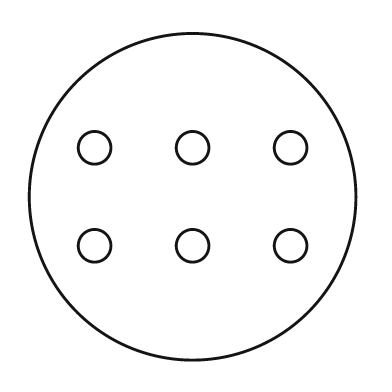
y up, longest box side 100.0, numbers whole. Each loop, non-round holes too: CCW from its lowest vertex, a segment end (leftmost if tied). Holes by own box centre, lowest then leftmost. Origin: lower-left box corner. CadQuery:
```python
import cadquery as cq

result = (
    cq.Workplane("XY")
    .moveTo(50.0, 50.0)
    .circle(50.0)
    .moveTo(20.0, 35.0)
    .circle(5.0)
    .moveTo(50.0, 35.0)
    .circle(5.0)
    .moveTo(80.0, 35.0)
    .circle(5.0)
    .moveTo(20.0, 65.0)
    .circle(5.0)
    .moveTo(50.0, 65.0)
    .circle(5.0)
    .moveTo(80.0, 65.0)
    .circle(5.0)
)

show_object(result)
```